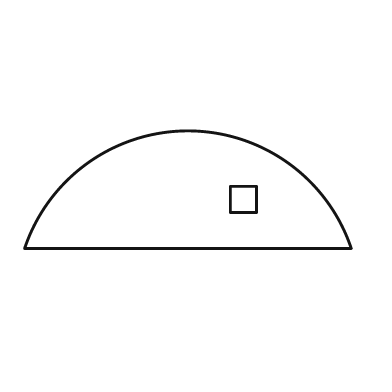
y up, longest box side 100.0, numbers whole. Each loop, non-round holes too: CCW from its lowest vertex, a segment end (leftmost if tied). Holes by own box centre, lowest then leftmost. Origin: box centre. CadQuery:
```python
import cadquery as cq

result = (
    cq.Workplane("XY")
    .moveTo(-50.0, -18.0)
    .lineTo(50.0, -18.0)
    .threePointArc((0.0, 18.0), (-50.0, -18.0))
    .close()
    .moveTo(13.0, -7.0)
    .lineTo(21.0, -7.0)
    .lineTo(21.0, 1.0)
    .lineTo(13.0, 1.0)
    .close()
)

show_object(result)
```